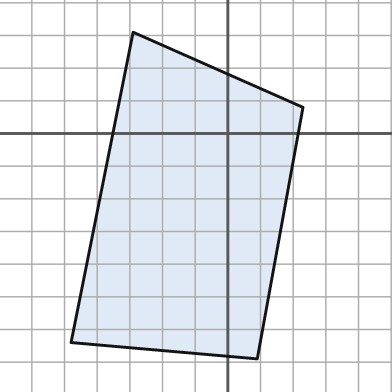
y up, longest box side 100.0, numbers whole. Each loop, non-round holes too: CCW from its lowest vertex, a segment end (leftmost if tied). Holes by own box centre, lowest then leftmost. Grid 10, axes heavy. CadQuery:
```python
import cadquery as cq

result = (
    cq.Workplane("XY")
    .moveTo(9.0, -69.0)
    .lineTo(23.0, 8.0)
    .lineTo(-29.0, 31.0)
    .lineTo(-48.0, -64.0)
    .close()
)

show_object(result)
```